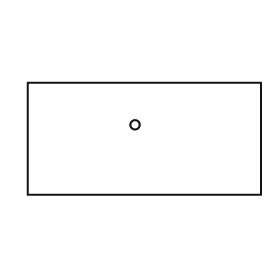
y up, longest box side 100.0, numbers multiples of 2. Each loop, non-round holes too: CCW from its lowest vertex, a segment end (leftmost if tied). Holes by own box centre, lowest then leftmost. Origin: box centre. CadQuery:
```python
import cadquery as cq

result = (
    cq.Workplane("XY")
    .moveTo(-50.0, -24.0)
    .lineTo(50.0, -24.0)
    .lineTo(50.0, 24.0)
    .lineTo(-50.0, 24.0)
    .close()
    .moveTo(-4.0, 6.0)
    .circle(2.0)
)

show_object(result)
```